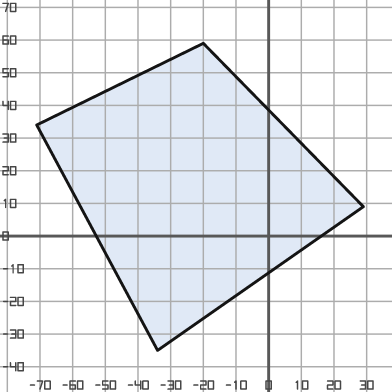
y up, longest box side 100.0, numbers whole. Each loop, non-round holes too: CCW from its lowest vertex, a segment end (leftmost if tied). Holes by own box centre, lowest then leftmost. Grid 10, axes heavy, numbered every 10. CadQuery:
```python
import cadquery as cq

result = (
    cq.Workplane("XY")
    .moveTo(-34.0, -35.0)
    .lineTo(29.0, 9.0)
    .lineTo(-20.0, 59.0)
    .lineTo(-71.0, 34.0)
    .close()
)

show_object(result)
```